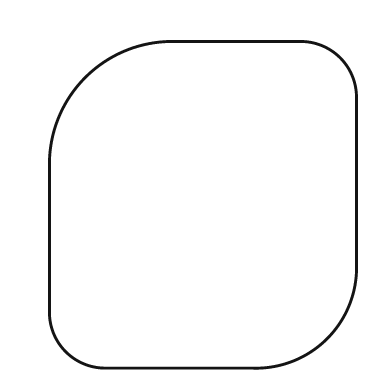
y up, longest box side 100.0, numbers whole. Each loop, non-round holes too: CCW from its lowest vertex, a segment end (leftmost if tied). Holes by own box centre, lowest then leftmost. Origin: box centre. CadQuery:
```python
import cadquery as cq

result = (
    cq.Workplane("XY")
    .moveTo(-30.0, -50.0)
    .lineTo(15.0, -50.0)
    .threePointArc((38.0, -41.0), (47.0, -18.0))
    .lineTo(47.0, 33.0)
    .threePointArc((42.0, 45.0), (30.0, 50.0))
    .lineTo(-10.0, 50.0)
    .threePointArc((-36.0, 39.0), (-47.0, 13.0))
    .lineTo(-47.0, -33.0)
    .threePointArc((-42.0, -45.0), (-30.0, -50.0))
    .close()
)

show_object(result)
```